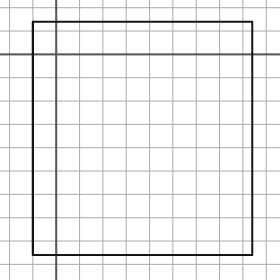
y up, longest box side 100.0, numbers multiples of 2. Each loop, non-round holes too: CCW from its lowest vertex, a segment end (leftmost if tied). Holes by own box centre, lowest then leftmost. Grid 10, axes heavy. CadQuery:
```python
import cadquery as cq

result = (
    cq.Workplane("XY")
    .moveTo(-10.0, -86.0)
    .lineTo(84.0, -86.0)
    .lineTo(84.0, 14.0)
    .lineTo(-10.0, 14.0)
    .close()
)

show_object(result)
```